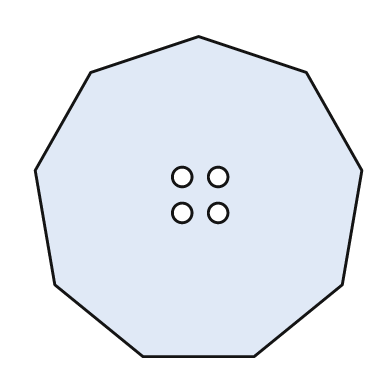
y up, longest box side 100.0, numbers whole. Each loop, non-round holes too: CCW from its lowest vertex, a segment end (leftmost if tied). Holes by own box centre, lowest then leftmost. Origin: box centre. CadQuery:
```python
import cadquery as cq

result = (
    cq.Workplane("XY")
    .moveTo(-17.0, -49.0)
    .lineTo(17.0, -49.0)
    .lineTo(44.0, -27.0)
    .lineTo(50.0, 8.0)
    .lineTo(33.0, 38.0)
    .lineTo(0.0, 49.0)
    .lineTo(-33.0, 38.0)
    .lineTo(-50.0, 8.0)
    .lineTo(-44.0, -27.0)
    .close()
    .moveTo(-5.0, -5.0)
    .circle(3.0)
    .moveTo(6.0, -5.0)
    .circle(3.0)
    .moveTo(-5.0, 6.0)
    .circle(3.0)
    .moveTo(6.0, 6.0)
    .circle(3.0)
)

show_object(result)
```